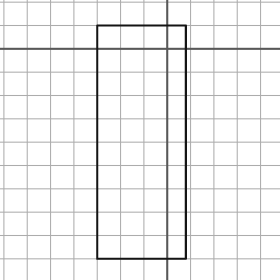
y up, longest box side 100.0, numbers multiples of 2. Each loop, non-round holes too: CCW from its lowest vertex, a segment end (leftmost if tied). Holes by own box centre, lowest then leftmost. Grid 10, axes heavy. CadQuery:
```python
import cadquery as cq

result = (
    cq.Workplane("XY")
    .moveTo(-30.0, -90.0)
    .lineTo(8.0, -90.0)
    .lineTo(8.0, 10.0)
    .lineTo(-30.0, 10.0)
    .close()
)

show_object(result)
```